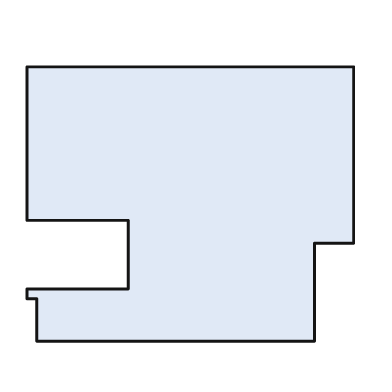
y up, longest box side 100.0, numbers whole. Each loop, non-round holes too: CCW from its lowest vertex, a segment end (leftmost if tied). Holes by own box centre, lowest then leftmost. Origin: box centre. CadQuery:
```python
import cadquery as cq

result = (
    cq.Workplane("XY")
    .moveTo(-47.0, -42.0)
    .lineTo(38.0, -42.0)
    .lineTo(38.0, -12.0)
    .lineTo(50.0, -12.0)
    .lineTo(50.0, 42.0)
    .lineTo(-50.0, 42.0)
    .lineTo(-50.0, -5.0)
    .lineTo(-19.0, -5.0)
    .lineTo(-19.0, -26.0)
    .lineTo(-50.0, -26.0)
    .lineTo(-50.0, -29.0)
    .lineTo(-47.0, -29.0)
    .close()
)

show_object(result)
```